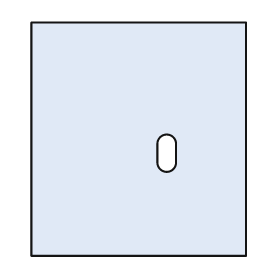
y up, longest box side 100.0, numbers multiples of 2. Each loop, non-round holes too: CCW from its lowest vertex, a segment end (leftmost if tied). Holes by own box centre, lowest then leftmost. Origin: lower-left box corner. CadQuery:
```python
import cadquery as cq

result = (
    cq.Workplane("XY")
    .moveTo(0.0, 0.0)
    .lineTo(92.0, 0.0)
    .lineTo(92.0, 100.0)
    .lineTo(0.0, 100.0)
    .close()
    .moveTo(54.0, 40.0)
    .threePointArc((58.0, 36.0), (62.0, 40.0))
    .lineTo(62.0, 48.0)
    .threePointArc((58.0, 52.0), (54.0, 48.0))
    .close()
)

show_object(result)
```